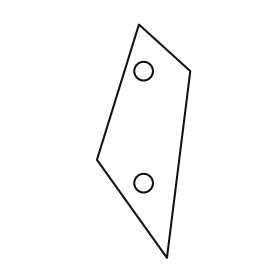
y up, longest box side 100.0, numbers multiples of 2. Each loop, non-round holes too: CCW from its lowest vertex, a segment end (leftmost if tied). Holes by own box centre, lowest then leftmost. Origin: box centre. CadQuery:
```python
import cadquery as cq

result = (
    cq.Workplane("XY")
    .moveTo(10.0, -50.0)
    .lineTo(20.0, 30.0)
    .lineTo(-2.0, 50.0)
    .lineTo(-20.0, -8.0)
    .close()
    .moveTo(0.0, -18.0)
    .circle(4.0)
    .moveTo(0.0, 30.0)
    .circle(4.0)
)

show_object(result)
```